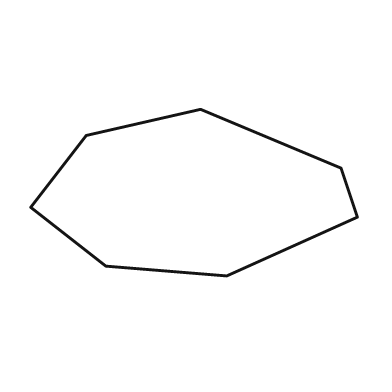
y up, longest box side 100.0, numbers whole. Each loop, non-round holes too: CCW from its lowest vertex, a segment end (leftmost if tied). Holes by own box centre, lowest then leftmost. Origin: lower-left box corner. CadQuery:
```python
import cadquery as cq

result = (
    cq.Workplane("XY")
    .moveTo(60.0, 0.0)
    .lineTo(100.0, 18.0)
    .lineTo(95.0, 33.0)
    .lineTo(52.0, 51.0)
    .lineTo(17.0, 43.0)
    .lineTo(0.0, 21.0)
    .lineTo(23.0, 3.0)
    .close()
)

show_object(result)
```